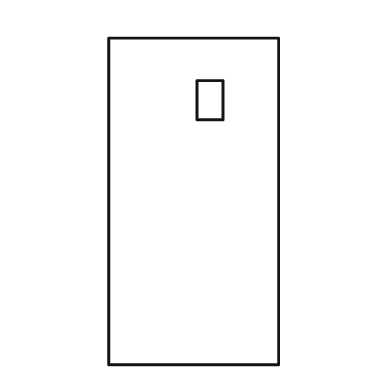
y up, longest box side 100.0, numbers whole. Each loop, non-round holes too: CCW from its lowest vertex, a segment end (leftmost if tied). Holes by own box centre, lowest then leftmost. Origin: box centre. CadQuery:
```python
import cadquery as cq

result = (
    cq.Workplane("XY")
    .moveTo(-26.0, -50.0)
    .lineTo(26.0, -50.0)
    .lineTo(26.0, 50.0)
    .lineTo(-26.0, 50.0)
    .close()
    .moveTo(1.0, 25.0)
    .lineTo(9.0, 25.0)
    .lineTo(9.0, 37.0)
    .lineTo(1.0, 37.0)
    .close()
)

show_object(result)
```